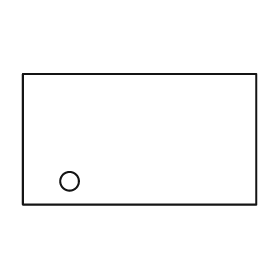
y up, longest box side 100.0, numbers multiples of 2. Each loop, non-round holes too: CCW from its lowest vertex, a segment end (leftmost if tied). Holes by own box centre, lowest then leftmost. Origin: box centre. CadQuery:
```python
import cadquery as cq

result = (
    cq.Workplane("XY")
    .moveTo(-50.0, -28.0)
    .lineTo(50.0, -28.0)
    .lineTo(50.0, 28.0)
    .lineTo(-50.0, 28.0)
    .close()
    .moveTo(-30.0, -18.0)
    .circle(4.0)
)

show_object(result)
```